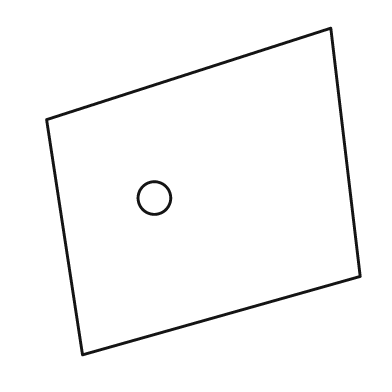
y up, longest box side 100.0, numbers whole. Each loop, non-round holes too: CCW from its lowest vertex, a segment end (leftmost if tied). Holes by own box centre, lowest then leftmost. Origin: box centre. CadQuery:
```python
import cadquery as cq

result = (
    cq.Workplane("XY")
    .moveTo(-37.0, -50.0)
    .lineTo(48.0, -26.0)
    .lineTo(39.0, 50.0)
    .lineTo(-48.0, 22.0)
    .close()
    .moveTo(-15.0, -2.0)
    .circle(5.0)
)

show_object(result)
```